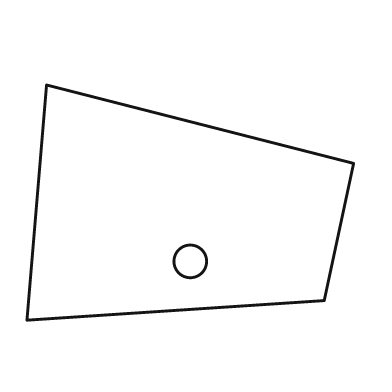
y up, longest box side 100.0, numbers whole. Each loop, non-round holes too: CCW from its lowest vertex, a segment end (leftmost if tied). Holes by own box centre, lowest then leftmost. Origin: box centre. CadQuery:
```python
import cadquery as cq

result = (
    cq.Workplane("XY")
    .moveTo(-50.0, -36.0)
    .lineTo(41.0, -30.0)
    .lineTo(50.0, 12.0)
    .lineTo(-44.0, 36.0)
    .close()
    .moveTo(0.0, -18.0)
    .circle(5.0)
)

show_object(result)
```